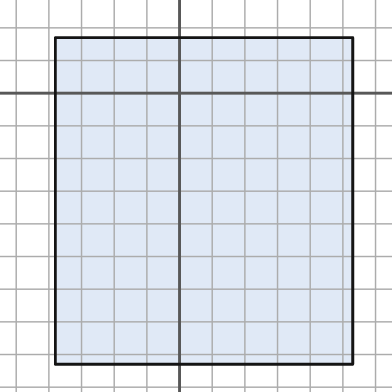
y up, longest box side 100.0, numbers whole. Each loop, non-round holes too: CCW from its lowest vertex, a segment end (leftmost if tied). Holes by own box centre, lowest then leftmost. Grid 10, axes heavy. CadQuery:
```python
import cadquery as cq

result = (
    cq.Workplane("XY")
    .moveTo(-38.0, -83.0)
    .lineTo(53.0, -83.0)
    .lineTo(53.0, 17.0)
    .lineTo(-38.0, 17.0)
    .close()
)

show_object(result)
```